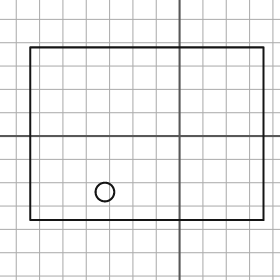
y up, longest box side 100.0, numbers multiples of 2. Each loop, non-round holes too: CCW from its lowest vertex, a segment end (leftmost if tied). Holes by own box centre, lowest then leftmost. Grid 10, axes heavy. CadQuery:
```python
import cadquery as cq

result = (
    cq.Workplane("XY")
    .moveTo(-64.0, -36.0)
    .lineTo(36.0, -36.0)
    .lineTo(36.0, 38.0)
    .lineTo(-64.0, 38.0)
    .close()
    .moveTo(-32.0, -24.0)
    .circle(4.0)
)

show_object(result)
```